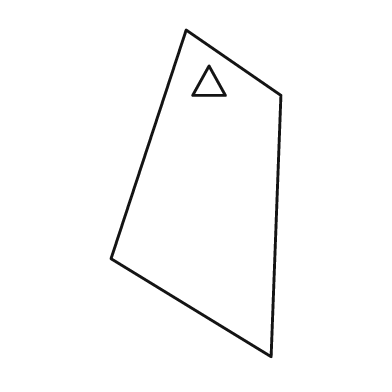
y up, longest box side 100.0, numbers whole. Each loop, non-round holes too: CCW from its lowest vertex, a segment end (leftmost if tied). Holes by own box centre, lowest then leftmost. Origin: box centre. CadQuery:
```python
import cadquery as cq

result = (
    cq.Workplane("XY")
    .moveTo(23.0, -50.0)
    .lineTo(26.0, 30.0)
    .lineTo(-3.0, 50.0)
    .lineTo(-26.0, -20.0)
    .close()
    .moveTo(-1.0, 30.0)
    .lineTo(9.0, 30.0)
    .lineTo(4.0, 39.0)
    .close()
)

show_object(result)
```